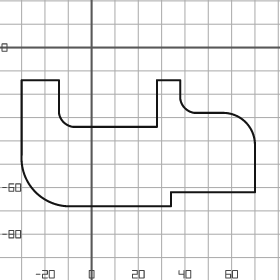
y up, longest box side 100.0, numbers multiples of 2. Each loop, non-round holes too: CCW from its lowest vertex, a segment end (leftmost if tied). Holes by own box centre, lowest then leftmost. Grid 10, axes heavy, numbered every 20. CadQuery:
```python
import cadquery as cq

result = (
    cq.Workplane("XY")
    .moveTo(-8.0, -68.0)
    .lineTo(34.0, -68.0)
    .lineTo(34.0, -62.0)
    .lineTo(70.0, -62.0)
    .lineTo(70.0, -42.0)
    .threePointArc((66.0, -32.0), (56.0, -28.0))
    .lineTo(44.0, -28.0)
    .threePointArc((40.0, -26.0), (38.0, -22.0))
    .lineTo(38.0, -14.0)
    .lineTo(28.0, -14.0)
    .lineTo(28.0, -34.0)
    .lineTo(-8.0, -34.0)
    .threePointArc((-12.0, -32.0), (-14.0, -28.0))
    .lineTo(-14.0, -14.0)
    .lineTo(-30.0, -14.0)
    .lineTo(-30.0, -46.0)
    .threePointArc((-24.0, -62.0), (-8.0, -68.0))
    .close()
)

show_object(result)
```